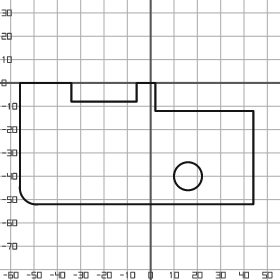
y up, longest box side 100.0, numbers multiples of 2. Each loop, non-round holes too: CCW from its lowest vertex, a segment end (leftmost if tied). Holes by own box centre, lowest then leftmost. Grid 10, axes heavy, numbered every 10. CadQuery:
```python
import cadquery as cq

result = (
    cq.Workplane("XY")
    .moveTo(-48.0, -52.0)
    .lineTo(44.0, -52.0)
    .lineTo(44.0, -12.0)
    .lineTo(2.0, -12.0)
    .lineTo(2.0, 0.0)
    .lineTo(-6.0, 0.0)
    .lineTo(-6.0, -8.0)
    .lineTo(-34.0, -8.0)
    .lineTo(-34.0, 0.0)
    .lineTo(-56.0, 0.0)
    .lineTo(-56.0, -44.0)
    .threePointArc((-54.0, -50.0), (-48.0, -52.0))
    .close()
    .moveTo(16.0, -40.0)
    .circle(6.0)
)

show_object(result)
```